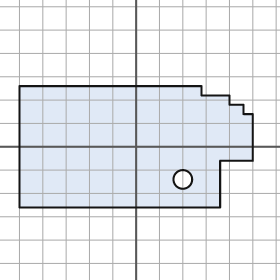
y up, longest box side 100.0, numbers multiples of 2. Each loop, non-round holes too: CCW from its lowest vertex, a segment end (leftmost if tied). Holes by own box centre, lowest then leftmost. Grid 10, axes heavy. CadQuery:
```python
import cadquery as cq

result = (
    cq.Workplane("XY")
    .moveTo(-50.0, -26.0)
    .lineTo(36.0, -26.0)
    .lineTo(36.0, -6.0)
    .lineTo(50.0, -6.0)
    .lineTo(50.0, 14.0)
    .lineTo(46.0, 14.0)
    .lineTo(46.0, 18.0)
    .lineTo(40.0, 18.0)
    .lineTo(40.0, 22.0)
    .lineTo(28.0, 22.0)
    .lineTo(28.0, 26.0)
    .lineTo(-50.0, 26.0)
    .close()
    .moveTo(20.0, -14.0)
    .circle(4.0)
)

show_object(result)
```